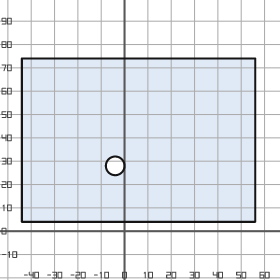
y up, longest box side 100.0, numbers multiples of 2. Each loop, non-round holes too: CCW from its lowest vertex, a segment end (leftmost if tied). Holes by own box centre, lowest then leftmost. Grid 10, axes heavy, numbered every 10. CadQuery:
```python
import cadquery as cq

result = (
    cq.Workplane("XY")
    .moveTo(-44.0, 4.0)
    .lineTo(56.0, 4.0)
    .lineTo(56.0, 74.0)
    .lineTo(-44.0, 74.0)
    .close()
    .moveTo(-4.0, 28.0)
    .circle(4.0)
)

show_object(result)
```